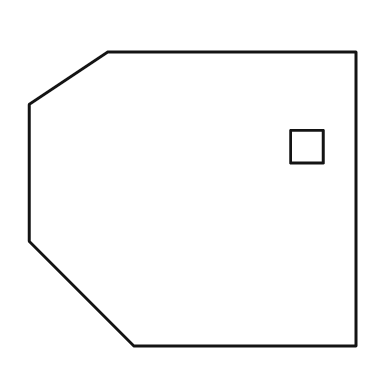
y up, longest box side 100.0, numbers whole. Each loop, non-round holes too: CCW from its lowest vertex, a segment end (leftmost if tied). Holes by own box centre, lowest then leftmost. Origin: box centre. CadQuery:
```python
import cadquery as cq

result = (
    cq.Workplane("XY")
    .moveTo(-18.0, -45.0)
    .lineTo(50.0, -45.0)
    .lineTo(50.0, 45.0)
    .lineTo(-26.0, 45.0)
    .lineTo(-50.0, 29.0)
    .lineTo(-50.0, -13.0)
    .close()
    .moveTo(30.0, 11.0)
    .lineTo(40.0, 11.0)
    .lineTo(40.0, 21.0)
    .lineTo(30.0, 21.0)
    .close()
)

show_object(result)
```